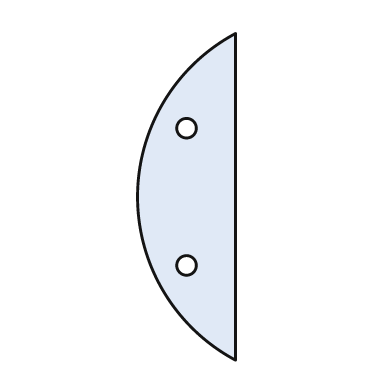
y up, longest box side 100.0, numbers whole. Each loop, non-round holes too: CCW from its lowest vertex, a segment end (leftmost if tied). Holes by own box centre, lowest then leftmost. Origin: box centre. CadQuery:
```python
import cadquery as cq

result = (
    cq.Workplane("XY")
    .moveTo(15.0, -50.0)
    .lineTo(15.0, 50.0)
    .threePointArc((-15.0, 0.0), (15.0, -50.0))
    .close()
    .moveTo(0.0, -21.0)
    .circle(3.0)
    .moveTo(0.0, 21.0)
    .circle(3.0)
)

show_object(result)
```